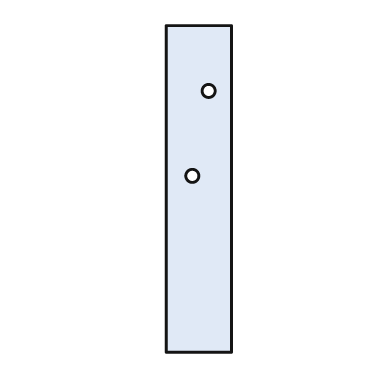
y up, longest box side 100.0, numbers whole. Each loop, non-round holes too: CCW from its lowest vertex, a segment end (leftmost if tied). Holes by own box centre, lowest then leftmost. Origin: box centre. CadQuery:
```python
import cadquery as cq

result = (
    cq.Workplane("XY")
    .moveTo(-10.0, -50.0)
    .lineTo(10.0, -50.0)
    .lineTo(10.0, 50.0)
    .lineTo(-10.0, 50.0)
    .close()
    .moveTo(-2.0, 4.0)
    .circle(2.0)
    .moveTo(3.0, 30.0)
    .circle(2.0)
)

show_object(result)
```